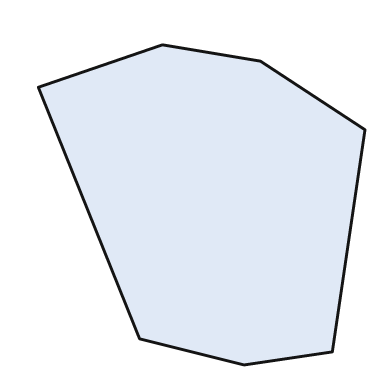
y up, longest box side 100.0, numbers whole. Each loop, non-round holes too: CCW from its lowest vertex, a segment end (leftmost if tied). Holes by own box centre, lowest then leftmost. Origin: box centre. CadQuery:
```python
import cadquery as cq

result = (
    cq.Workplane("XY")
    .moveTo(13.0, -49.0)
    .lineTo(40.0, -45.0)
    .lineTo(50.0, 23.0)
    .lineTo(18.0, 44.0)
    .lineTo(-12.0, 49.0)
    .lineTo(-50.0, 36.0)
    .lineTo(-19.0, -41.0)
    .close()
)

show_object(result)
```